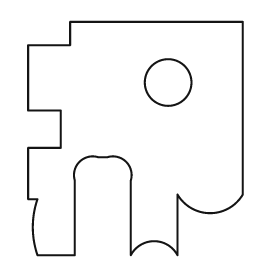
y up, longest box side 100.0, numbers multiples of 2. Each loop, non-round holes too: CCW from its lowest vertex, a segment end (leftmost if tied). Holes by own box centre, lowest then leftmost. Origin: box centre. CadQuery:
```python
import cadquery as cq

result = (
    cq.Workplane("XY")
    .moveTo(-42.0, -50.0)
    .lineTo(-26.0, -50.0)
    .lineTo(-26.0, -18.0)
    .threePointArc((-24.0, -10.0), (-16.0, -8.0))
    .lineTo(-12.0, -8.0)
    .threePointArc((-4.0, -10.0), (-2.0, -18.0))
    .lineTo(-2.0, -50.0)
    .threePointArc((8.0, -44.0), (18.0, -50.0))
    .lineTo(18.0, -24.0)
    .threePointArc((32.0, -32.0), (46.0, -24.0))
    .lineTo(46.0, 50.0)
    .lineTo(-28.0, 50.0)
    .lineTo(-28.0, 40.0)
    .lineTo(-46.0, 40.0)
    .lineTo(-46.0, 12.0)
    .lineTo(-32.0, 12.0)
    .lineTo(-32.0, -4.0)
    .lineTo(-46.0, -4.0)
    .lineTo(-46.0, -26.0)
    .lineTo(-42.0, -26.0)
    .threePointArc((-44.0, -38.0), (-42.0, -50.0))
    .close()
    .moveTo(14.0, 24.0)
    .circle(10.0)
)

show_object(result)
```